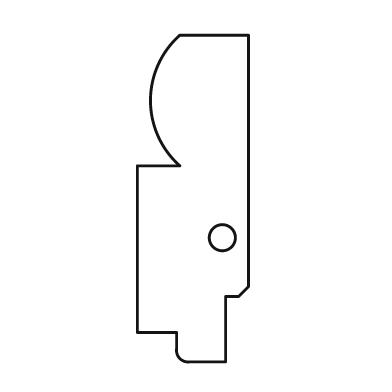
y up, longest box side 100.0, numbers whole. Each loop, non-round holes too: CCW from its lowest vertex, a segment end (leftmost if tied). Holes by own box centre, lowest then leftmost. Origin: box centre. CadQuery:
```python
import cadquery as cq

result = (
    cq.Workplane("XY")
    .moveTo(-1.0, -50.0)
    .lineTo(10.0, -50.0)
    .lineTo(10.0, -30.0)
    .lineTo(14.0, -30.0)
    .lineTo(17.0, -27.0)
    .lineTo(17.0, 50.0)
    .lineTo(-4.0, 50.0)
    .threePointArc((-13.0, 30.0), (-4.0, 10.0))
    .lineTo(-17.0, 10.0)
    .lineTo(-17.0, -41.0)
    .lineTo(-5.0, -41.0)
    .lineTo(-5.0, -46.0)
    .threePointArc((-4.0, -49.0), (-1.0, -50.0))
    .close()
    .moveTo(9.0, -12.0)
    .circle(4.0)
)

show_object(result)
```